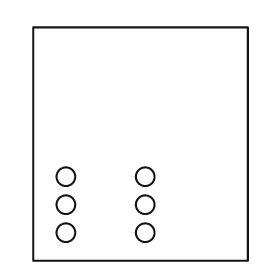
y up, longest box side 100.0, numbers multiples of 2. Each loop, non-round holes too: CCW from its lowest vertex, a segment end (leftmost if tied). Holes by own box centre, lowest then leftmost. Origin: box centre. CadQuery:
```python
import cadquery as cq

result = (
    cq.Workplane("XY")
    .moveTo(-46.0, -50.0)
    .lineTo(46.0, -50.0)
    .lineTo(46.0, 50.0)
    .lineTo(-46.0, 50.0)
    .close()
    .moveTo(-32.0, -38.0)
    .circle(4.0)
    .moveTo(2.0, -38.0)
    .circle(4.0)
    .moveTo(-32.0, -26.0)
    .circle(4.0)
    .moveTo(2.0, -26.0)
    .circle(4.0)
    .moveTo(-32.0, -14.0)
    .circle(4.0)
    .moveTo(2.0, -14.0)
    .circle(4.0)
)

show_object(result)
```